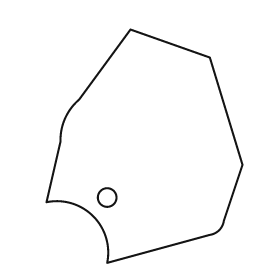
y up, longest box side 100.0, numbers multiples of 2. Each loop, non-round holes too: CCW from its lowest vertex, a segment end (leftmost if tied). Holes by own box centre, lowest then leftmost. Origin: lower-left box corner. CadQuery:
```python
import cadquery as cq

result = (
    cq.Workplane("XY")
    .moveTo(26.0, 0.0)
    .lineTo(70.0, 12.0)
    .threePointArc((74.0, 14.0), (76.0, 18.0))
    .lineTo(84.0, 42.0)
    .lineTo(70.0, 88.0)
    .lineTo(36.0, 100.0)
    .lineTo(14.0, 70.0)
    .threePointArc((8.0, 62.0), (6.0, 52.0))
    .lineTo(0.0, 26.0)
    .threePointArc((20.0, 20.0), (26.0, 0.0))
    .close()
    .moveTo(26.0, 28.0)
    .circle(4.0)
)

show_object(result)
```